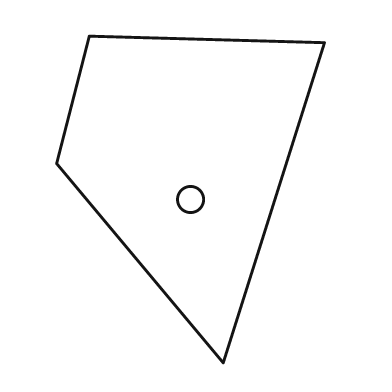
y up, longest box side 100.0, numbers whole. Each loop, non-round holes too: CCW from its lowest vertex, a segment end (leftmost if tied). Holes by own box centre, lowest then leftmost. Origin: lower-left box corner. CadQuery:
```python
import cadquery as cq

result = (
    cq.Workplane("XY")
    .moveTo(51.0, 0.0)
    .lineTo(82.0, 98.0)
    .lineTo(10.0, 100.0)
    .lineTo(0.0, 61.0)
    .close()
    .moveTo(41.0, 50.0)
    .circle(4.0)
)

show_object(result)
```